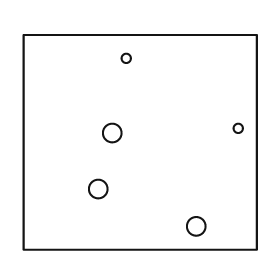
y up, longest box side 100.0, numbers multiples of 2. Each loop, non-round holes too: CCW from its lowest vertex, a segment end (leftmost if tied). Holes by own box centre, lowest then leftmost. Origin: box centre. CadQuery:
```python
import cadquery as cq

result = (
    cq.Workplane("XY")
    .moveTo(-50.0, -46.0)
    .lineTo(50.0, -46.0)
    .lineTo(50.0, 46.0)
    .lineTo(-50.0, 46.0)
    .close()
    .moveTo(24.0, -36.0)
    .circle(4.0)
    .moveTo(-18.0, -20.0)
    .circle(4.0)
    .moveTo(-12.0, 4.0)
    .circle(4.0)
    .moveTo(42.0, 6.0)
    .circle(2.0)
    .moveTo(-6.0, 36.0)
    .circle(2.0)
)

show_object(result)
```